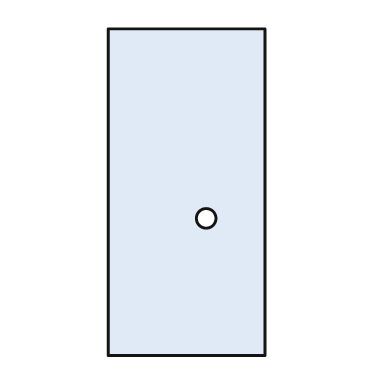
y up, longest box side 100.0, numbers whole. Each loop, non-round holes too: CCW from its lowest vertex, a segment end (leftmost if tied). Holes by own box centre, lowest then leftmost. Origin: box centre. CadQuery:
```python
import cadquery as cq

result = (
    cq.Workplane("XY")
    .moveTo(-24.0, -50.0)
    .lineTo(24.0, -50.0)
    .lineTo(24.0, 50.0)
    .lineTo(-24.0, 50.0)
    .close()
    .moveTo(6.0, -8.0)
    .circle(3.0)
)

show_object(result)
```